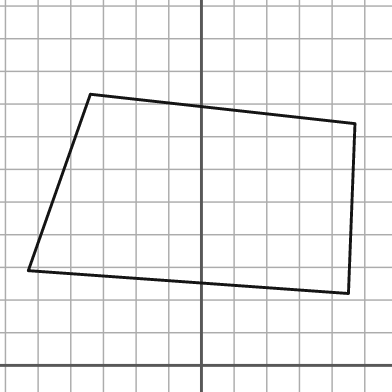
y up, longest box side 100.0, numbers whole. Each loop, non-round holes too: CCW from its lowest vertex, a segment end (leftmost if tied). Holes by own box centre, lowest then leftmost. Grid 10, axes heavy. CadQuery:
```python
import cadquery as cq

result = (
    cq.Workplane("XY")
    .moveTo(45.0, 22.0)
    .lineTo(47.0, 74.0)
    .lineTo(-34.0, 83.0)
    .lineTo(-53.0, 29.0)
    .close()
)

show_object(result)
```